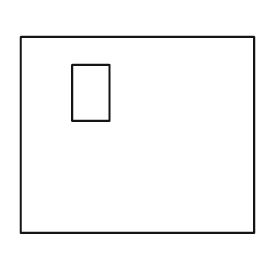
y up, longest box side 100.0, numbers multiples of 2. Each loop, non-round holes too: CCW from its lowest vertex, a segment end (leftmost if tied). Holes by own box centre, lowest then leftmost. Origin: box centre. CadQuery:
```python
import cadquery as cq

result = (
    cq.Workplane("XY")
    .moveTo(-50.0, -42.0)
    .lineTo(50.0, -42.0)
    .lineTo(50.0, 42.0)
    .lineTo(-50.0, 42.0)
    .close()
    .moveTo(-28.0, 6.0)
    .lineTo(-12.0, 6.0)
    .lineTo(-12.0, 30.0)
    .lineTo(-28.0, 30.0)
    .close()
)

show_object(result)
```